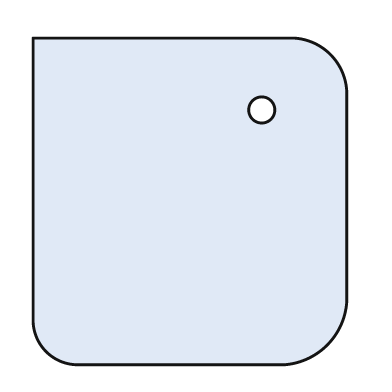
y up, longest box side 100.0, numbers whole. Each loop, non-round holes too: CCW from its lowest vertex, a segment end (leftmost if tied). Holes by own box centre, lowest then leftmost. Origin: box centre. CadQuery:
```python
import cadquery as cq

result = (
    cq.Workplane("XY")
    .moveTo(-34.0, -50.0)
    .lineTo(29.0, -50.0)
    .threePointArc((42.0, -44.0), (48.0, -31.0))
    .lineTo(48.0, 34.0)
    .threePointArc((43.0, 45.0), (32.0, 50.0))
    .lineTo(-48.0, 50.0)
    .lineTo(-48.0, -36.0)
    .threePointArc((-44.0, -46.0), (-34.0, -50.0))
    .close()
    .moveTo(22.0, 28.0)
    .circle(4.0)
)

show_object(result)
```